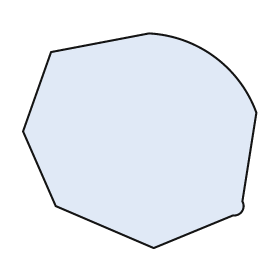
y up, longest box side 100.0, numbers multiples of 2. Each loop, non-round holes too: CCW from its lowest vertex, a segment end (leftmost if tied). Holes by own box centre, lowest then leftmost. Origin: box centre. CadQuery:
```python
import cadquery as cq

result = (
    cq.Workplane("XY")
    .moveTo(6.0, -46.0)
    .lineTo(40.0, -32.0)
    .threePointArc((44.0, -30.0), (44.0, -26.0))
    .lineTo(50.0, 12.0)
    .threePointArc((32.0, 36.0), (4.0, 46.0))
    .lineTo(-38.0, 38.0)
    .lineTo(-50.0, 4.0)
    .lineTo(-36.0, -28.0)
    .close()
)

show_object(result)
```